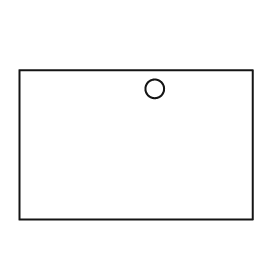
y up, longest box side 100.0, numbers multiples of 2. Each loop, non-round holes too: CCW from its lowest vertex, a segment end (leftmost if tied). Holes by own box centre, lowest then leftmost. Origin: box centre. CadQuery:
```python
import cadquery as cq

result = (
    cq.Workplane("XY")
    .moveTo(-50.0, -32.0)
    .lineTo(50.0, -32.0)
    .lineTo(50.0, 32.0)
    .lineTo(-50.0, 32.0)
    .close()
    .moveTo(8.0, 24.0)
    .circle(4.0)
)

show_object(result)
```